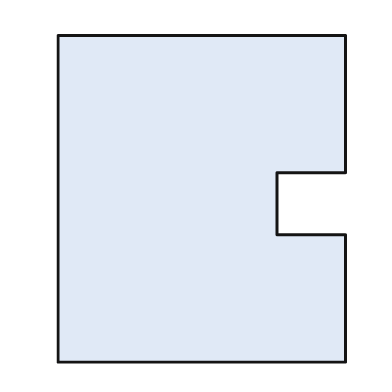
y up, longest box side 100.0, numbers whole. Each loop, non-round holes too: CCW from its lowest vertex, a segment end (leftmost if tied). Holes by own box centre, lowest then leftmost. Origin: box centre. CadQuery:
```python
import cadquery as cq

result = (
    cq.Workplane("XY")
    .moveTo(-44.0, -50.0)
    .lineTo(44.0, -50.0)
    .lineTo(44.0, -11.0)
    .lineTo(23.0, -11.0)
    .lineTo(23.0, 8.0)
    .lineTo(44.0, 8.0)
    .lineTo(44.0, 50.0)
    .lineTo(-44.0, 50.0)
    .close()
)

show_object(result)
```